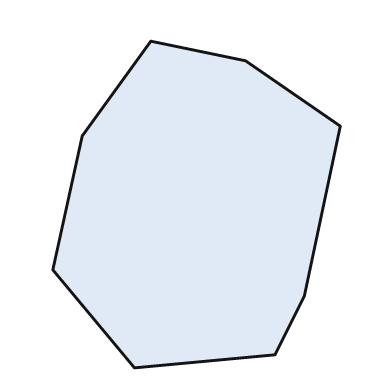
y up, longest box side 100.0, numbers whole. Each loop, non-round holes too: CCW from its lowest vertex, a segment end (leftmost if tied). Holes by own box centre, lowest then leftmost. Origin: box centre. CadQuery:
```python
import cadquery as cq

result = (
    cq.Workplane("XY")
    .moveTo(-19.0, -50.0)
    .lineTo(24.0, -46.0)
    .lineTo(33.0, -28.0)
    .lineTo(44.0, 24.0)
    .lineTo(15.0, 44.0)
    .lineTo(-14.0, 50.0)
    .lineTo(-35.0, 21.0)
    .lineTo(-44.0, -20.0)
    .close()
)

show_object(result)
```